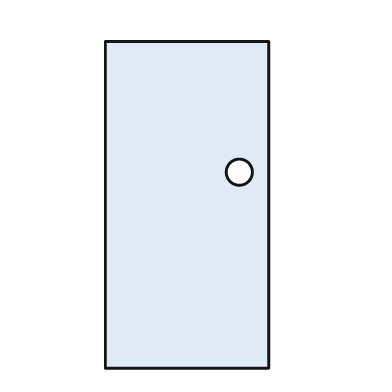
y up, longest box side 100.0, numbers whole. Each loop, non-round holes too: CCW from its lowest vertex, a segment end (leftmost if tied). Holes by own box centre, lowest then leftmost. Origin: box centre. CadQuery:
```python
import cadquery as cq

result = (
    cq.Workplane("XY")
    .moveTo(-25.0, -50.0)
    .lineTo(25.0, -50.0)
    .lineTo(25.0, 50.0)
    .lineTo(-25.0, 50.0)
    .close()
    .moveTo(16.0, 10.0)
    .circle(4.0)
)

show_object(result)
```